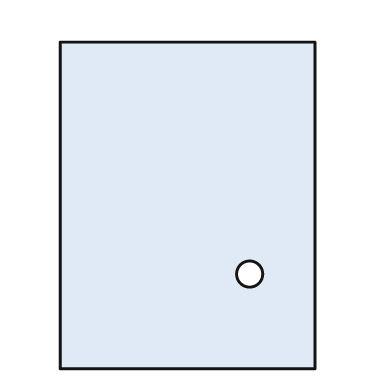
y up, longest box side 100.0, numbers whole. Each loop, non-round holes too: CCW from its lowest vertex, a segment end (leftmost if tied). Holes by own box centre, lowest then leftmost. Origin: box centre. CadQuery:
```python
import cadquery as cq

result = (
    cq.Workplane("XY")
    .moveTo(-39.0, -50.0)
    .lineTo(39.0, -50.0)
    .lineTo(39.0, 50.0)
    .lineTo(-39.0, 50.0)
    .close()
    .moveTo(19.0, -21.0)
    .circle(4.0)
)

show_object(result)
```